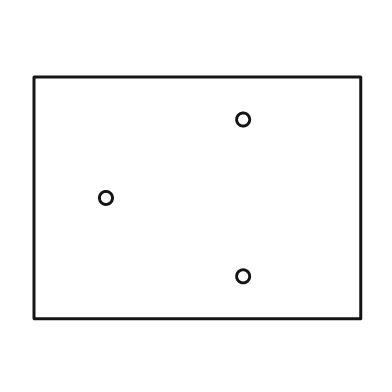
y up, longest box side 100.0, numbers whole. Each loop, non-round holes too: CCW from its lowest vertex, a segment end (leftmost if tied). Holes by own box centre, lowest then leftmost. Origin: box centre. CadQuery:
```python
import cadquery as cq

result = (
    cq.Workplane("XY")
    .moveTo(-50.0, -37.0)
    .lineTo(50.0, -37.0)
    .lineTo(50.0, 37.0)
    .lineTo(-50.0, 37.0)
    .close()
    .moveTo(14.0, -24.0)
    .circle(2.0)
    .moveTo(-28.0, 0.0)
    .circle(2.0)
    .moveTo(14.0, 24.0)
    .circle(2.0)
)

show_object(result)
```